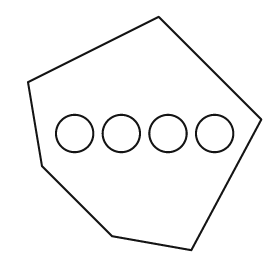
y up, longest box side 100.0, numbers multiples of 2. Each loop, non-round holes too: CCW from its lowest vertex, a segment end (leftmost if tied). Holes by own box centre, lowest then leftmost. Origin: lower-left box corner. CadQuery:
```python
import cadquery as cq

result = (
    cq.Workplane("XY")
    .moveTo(70.0, 0.0)
    .lineTo(100.0, 56.0)
    .lineTo(56.0, 100.0)
    .lineTo(0.0, 72.0)
    .lineTo(6.0, 36.0)
    .lineTo(36.0, 6.0)
    .close()
    .moveTo(20.0, 50.0)
    .circle(8.0)
    .moveTo(40.0, 50.0)
    .circle(8.0)
    .moveTo(60.0, 50.0)
    .circle(8.0)
    .moveTo(80.0, 50.0)
    .circle(8.0)
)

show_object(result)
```